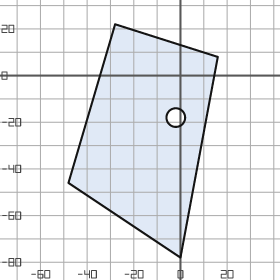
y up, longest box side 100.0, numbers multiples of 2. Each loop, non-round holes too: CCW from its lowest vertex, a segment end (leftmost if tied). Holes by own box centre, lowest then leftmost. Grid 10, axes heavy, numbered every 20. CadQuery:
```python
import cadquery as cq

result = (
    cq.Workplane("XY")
    .moveTo(0.0, -78.0)
    .lineTo(16.0, 8.0)
    .lineTo(-28.0, 22.0)
    .lineTo(-48.0, -46.0)
    .close()
    .moveTo(-2.0, -18.0)
    .circle(4.0)
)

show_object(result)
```